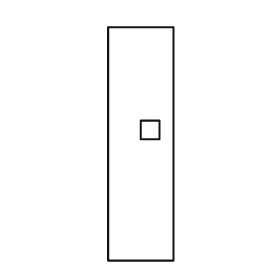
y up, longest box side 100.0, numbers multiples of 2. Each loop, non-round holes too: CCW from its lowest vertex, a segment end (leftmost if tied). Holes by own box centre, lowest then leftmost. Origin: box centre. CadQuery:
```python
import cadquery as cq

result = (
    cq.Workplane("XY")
    .moveTo(-14.0, -50.0)
    .lineTo(14.0, -50.0)
    .lineTo(14.0, 50.0)
    .lineTo(-14.0, 50.0)
    .close()
    .moveTo(0.0, 2.0)
    .lineTo(8.0, 2.0)
    .lineTo(8.0, 10.0)
    .lineTo(0.0, 10.0)
    .close()
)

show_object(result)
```